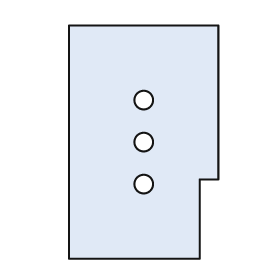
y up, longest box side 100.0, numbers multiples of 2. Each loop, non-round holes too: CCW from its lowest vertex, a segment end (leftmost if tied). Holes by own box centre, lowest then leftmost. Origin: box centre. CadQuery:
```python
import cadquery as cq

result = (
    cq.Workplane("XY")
    .moveTo(-32.0, -50.0)
    .lineTo(24.0, -50.0)
    .lineTo(24.0, -16.0)
    .lineTo(32.0, -16.0)
    .lineTo(32.0, 50.0)
    .lineTo(-32.0, 50.0)
    .close()
    .moveTo(0.0, -18.0)
    .circle(4.0)
    .moveTo(0.0, 0.0)
    .circle(4.0)
    .moveTo(0.0, 18.0)
    .circle(4.0)
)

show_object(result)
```